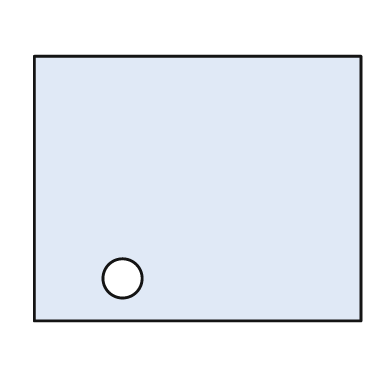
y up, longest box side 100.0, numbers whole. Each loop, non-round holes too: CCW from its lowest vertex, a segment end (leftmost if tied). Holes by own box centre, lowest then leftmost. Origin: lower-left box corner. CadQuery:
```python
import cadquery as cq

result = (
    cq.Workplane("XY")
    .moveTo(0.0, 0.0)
    .lineTo(100.0, 0.0)
    .lineTo(100.0, 81.0)
    .lineTo(0.0, 81.0)
    .close()
    .moveTo(27.0, 13.0)
    .circle(6.0)
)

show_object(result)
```